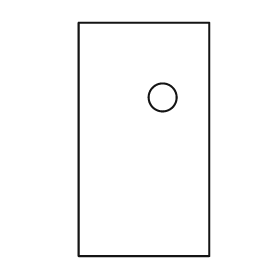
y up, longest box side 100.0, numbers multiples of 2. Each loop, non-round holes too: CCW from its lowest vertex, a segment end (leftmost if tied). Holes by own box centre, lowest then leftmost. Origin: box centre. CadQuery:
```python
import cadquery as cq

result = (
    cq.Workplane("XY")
    .moveTo(-28.0, -50.0)
    .lineTo(28.0, -50.0)
    .lineTo(28.0, 50.0)
    .lineTo(-28.0, 50.0)
    .close()
    .moveTo(8.0, 18.0)
    .circle(6.0)
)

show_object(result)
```